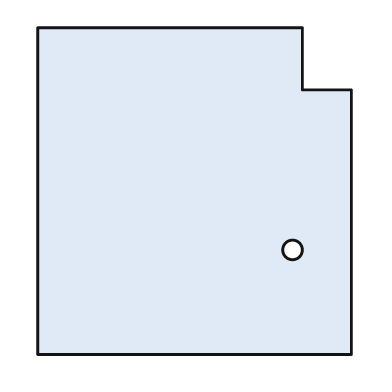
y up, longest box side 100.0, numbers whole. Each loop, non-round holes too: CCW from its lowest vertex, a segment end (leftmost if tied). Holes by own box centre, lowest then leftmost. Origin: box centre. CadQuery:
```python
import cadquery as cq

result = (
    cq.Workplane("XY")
    .moveTo(-48.0, -50.0)
    .lineTo(48.0, -50.0)
    .lineTo(48.0, 31.0)
    .lineTo(33.0, 31.0)
    .lineTo(33.0, 50.0)
    .lineTo(-48.0, 50.0)
    .close()
    .moveTo(30.0, -18.0)
    .circle(3.0)
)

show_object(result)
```